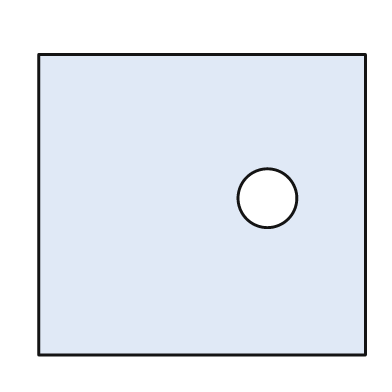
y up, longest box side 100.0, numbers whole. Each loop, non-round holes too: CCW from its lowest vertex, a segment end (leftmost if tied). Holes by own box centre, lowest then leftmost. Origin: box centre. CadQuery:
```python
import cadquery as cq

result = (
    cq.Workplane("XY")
    .moveTo(-50.0, -46.0)
    .lineTo(50.0, -46.0)
    .lineTo(50.0, 46.0)
    .lineTo(-50.0, 46.0)
    .close()
    .moveTo(20.0, 2.0)
    .circle(9.0)
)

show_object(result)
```